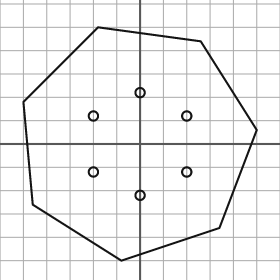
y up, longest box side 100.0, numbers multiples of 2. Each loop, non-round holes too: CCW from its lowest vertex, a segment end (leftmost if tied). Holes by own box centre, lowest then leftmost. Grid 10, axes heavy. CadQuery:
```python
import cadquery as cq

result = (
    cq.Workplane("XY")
    .moveTo(-8.0, -50.0)
    .lineTo(34.0, -36.0)
    .lineTo(50.0, 6.0)
    .lineTo(26.0, 44.0)
    .lineTo(-18.0, 50.0)
    .lineTo(-50.0, 18.0)
    .lineTo(-46.0, -26.0)
    .close()
    .moveTo(0.0, -22.0)
    .circle(2.0)
    .moveTo(-20.0, -12.0)
    .circle(2.0)
    .moveTo(20.0, -12.0)
    .circle(2.0)
    .moveTo(-20.0, 12.0)
    .circle(2.0)
    .moveTo(20.0, 12.0)
    .circle(2.0)
    .moveTo(0.0, 22.0)
    .circle(2.0)
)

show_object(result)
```